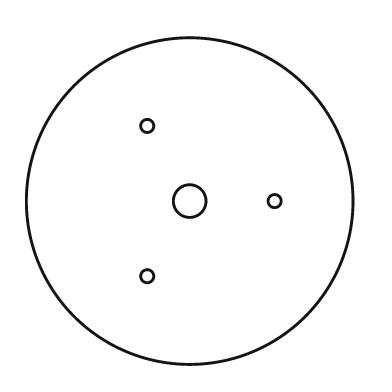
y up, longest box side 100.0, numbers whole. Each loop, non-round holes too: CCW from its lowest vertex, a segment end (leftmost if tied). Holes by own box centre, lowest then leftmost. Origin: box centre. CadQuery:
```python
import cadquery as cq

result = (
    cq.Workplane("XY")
    .moveTo(0.0, 0.0)
    .circle(50.0)
    .moveTo(-13.0, -23.0)
    .circle(2.0)
    .moveTo(0.0, 0.0)
    .circle(5.0)
    .moveTo(26.0, 0.0)
    .circle(2.0)
    .moveTo(-13.0, 23.0)
    .circle(2.0)
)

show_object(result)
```